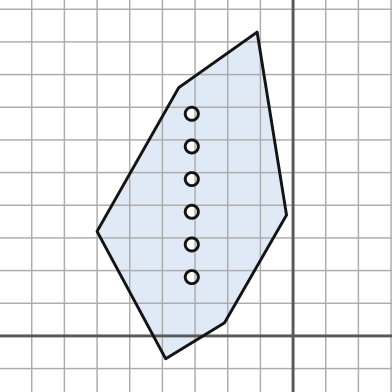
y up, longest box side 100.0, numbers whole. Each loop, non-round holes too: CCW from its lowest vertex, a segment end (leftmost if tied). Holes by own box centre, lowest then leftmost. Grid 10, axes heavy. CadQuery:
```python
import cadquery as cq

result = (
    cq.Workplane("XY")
    .moveTo(-39.0, -7.0)
    .lineTo(-21.0, 4.0)
    .lineTo(-2.0, 37.0)
    .lineTo(-11.0, 93.0)
    .lineTo(-35.0, 76.0)
    .lineTo(-60.0, 32.0)
    .close()
    .moveTo(-31.0, 18.0)
    .circle(2.0)
    .moveTo(-31.0, 28.0)
    .circle(2.0)
    .moveTo(-31.0, 38.0)
    .circle(2.0)
    .moveTo(-31.0, 48.0)
    .circle(2.0)
    .moveTo(-31.0, 58.0)
    .circle(2.0)
    .moveTo(-31.0, 68.0)
    .circle(2.0)
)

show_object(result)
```